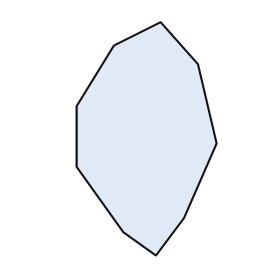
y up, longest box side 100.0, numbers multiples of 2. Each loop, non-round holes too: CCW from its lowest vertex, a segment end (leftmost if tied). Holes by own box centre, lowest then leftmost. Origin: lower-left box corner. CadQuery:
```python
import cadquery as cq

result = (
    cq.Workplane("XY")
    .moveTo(34.0, 0.0)
    .lineTo(46.0, 16.0)
    .lineTo(60.0, 48.0)
    .lineTo(52.0, 82.0)
    .lineTo(36.0, 100.0)
    .lineTo(16.0, 90.0)
    .lineTo(0.0, 64.0)
    .lineTo(0.0, 38.0)
    .lineTo(20.0, 10.0)
    .close()
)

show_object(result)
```